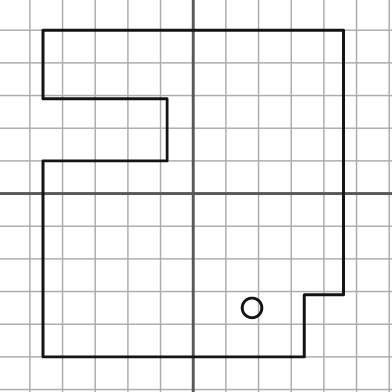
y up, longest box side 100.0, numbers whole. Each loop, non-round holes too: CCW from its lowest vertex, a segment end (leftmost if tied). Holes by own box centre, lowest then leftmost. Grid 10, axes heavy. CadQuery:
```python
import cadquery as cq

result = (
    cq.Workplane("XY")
    .moveTo(-46.0, -50.0)
    .lineTo(34.0, -50.0)
    .lineTo(34.0, -31.0)
    .lineTo(46.0, -31.0)
    .lineTo(46.0, 50.0)
    .lineTo(-46.0, 50.0)
    .lineTo(-46.0, 29.0)
    .lineTo(-8.0, 29.0)
    .lineTo(-8.0, 10.0)
    .lineTo(-46.0, 10.0)
    .close()
    .moveTo(18.0, -35.0)
    .circle(3.0)
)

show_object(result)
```